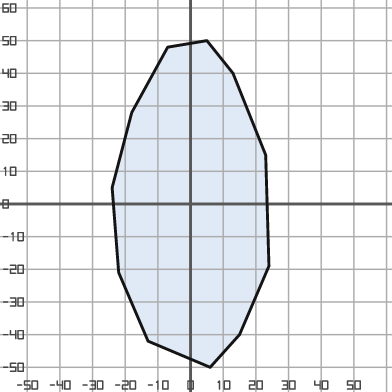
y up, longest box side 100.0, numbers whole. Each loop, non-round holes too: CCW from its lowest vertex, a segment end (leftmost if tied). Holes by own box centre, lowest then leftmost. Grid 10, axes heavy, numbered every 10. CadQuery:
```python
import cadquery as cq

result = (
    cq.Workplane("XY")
    .moveTo(6.0, -50.0)
    .lineTo(15.0, -40.0)
    .lineTo(24.0, -19.0)
    .lineTo(23.0, 15.0)
    .lineTo(13.0, 40.0)
    .lineTo(5.0, 50.0)
    .lineTo(-7.0, 48.0)
    .lineTo(-18.0, 28.0)
    .lineTo(-24.0, 5.0)
    .lineTo(-22.0, -21.0)
    .lineTo(-13.0, -42.0)
    .close()
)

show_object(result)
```